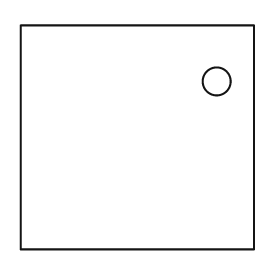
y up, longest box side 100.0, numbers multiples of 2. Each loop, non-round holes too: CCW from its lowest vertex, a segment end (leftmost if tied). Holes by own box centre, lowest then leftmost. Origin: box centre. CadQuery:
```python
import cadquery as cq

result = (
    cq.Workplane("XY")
    .moveTo(-50.0, -48.0)
    .lineTo(50.0, -48.0)
    .lineTo(50.0, 48.0)
    .lineTo(-50.0, 48.0)
    .close()
    .moveTo(34.0, 24.0)
    .circle(6.0)
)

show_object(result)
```